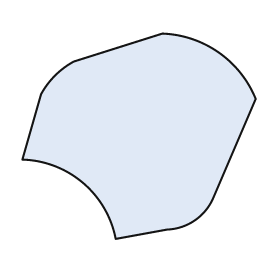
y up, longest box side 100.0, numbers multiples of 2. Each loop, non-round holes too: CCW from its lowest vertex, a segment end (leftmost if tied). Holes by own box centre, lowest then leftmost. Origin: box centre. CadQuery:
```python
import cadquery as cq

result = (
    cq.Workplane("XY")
    .moveTo(-10.0, -44.0)
    .lineTo(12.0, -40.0)
    .threePointArc((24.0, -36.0), (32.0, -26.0))
    .lineTo(50.0, 16.0)
    .threePointArc((34.0, 36.0), (10.0, 44.0))
    .lineTo(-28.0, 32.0)
    .threePointArc((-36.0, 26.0), (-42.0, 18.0))
    .lineTo(-50.0, -10.0)
    .threePointArc((-24.0, -20.0), (-10.0, -44.0))
    .close()
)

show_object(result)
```